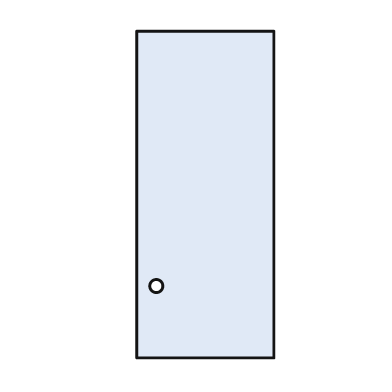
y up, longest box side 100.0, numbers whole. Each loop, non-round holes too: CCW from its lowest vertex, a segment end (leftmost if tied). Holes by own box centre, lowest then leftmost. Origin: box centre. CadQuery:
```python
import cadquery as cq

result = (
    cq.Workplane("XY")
    .moveTo(-21.0, -50.0)
    .lineTo(21.0, -50.0)
    .lineTo(21.0, 50.0)
    .lineTo(-21.0, 50.0)
    .close()
    .moveTo(-15.0, -28.0)
    .circle(2.0)
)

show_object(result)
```